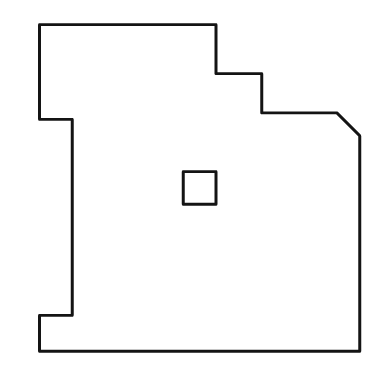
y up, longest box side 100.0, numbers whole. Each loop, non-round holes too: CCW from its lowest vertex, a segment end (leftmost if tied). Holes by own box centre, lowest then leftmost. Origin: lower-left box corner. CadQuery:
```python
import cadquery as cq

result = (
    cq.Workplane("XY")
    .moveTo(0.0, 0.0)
    .lineTo(98.0, 0.0)
    .lineTo(98.0, 66.0)
    .lineTo(91.0, 73.0)
    .lineTo(68.0, 73.0)
    .lineTo(68.0, 85.0)
    .lineTo(54.0, 85.0)
    .lineTo(54.0, 100.0)
    .lineTo(0.0, 100.0)
    .lineTo(0.0, 71.0)
    .lineTo(10.0, 71.0)
    .lineTo(10.0, 11.0)
    .lineTo(0.0, 11.0)
    .close()
    .moveTo(44.0, 45.0)
    .lineTo(54.0, 45.0)
    .lineTo(54.0, 55.0)
    .lineTo(44.0, 55.0)
    .close()
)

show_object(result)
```